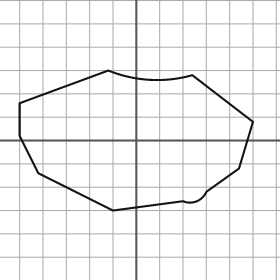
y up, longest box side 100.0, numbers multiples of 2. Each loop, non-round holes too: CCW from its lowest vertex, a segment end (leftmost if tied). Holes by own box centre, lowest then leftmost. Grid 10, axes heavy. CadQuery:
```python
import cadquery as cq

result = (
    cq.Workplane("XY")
    .moveTo(-10.0, -30.0)
    .lineTo(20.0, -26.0)
    .threePointArc((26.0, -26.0), (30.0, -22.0))
    .lineTo(44.0, -12.0)
    .lineTo(50.0, 8.0)
    .lineTo(24.0, 28.0)
    .threePointArc((6.0, 26.0), (-12.0, 30.0))
    .lineTo(-50.0, 16.0)
    .lineTo(-50.0, 2.0)
    .lineTo(-42.0, -14.0)
    .close()
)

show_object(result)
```